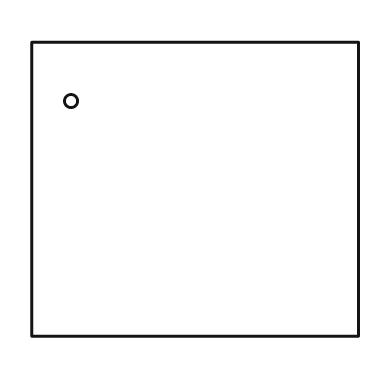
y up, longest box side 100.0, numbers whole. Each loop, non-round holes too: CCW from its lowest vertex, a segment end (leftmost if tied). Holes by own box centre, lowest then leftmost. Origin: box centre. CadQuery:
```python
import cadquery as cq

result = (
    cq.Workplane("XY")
    .moveTo(-50.0, -45.0)
    .lineTo(50.0, -45.0)
    .lineTo(50.0, 45.0)
    .lineTo(-50.0, 45.0)
    .close()
    .moveTo(-38.0, 27.0)
    .circle(2.0)
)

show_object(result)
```